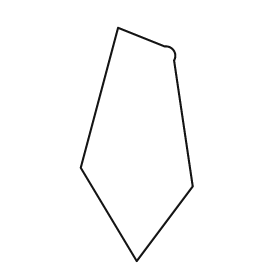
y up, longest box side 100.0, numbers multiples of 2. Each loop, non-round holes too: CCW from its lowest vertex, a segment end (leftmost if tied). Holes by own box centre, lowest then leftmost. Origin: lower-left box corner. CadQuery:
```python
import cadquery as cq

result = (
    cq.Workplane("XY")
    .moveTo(24.0, 0.0)
    .lineTo(48.0, 32.0)
    .lineTo(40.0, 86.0)
    .threePointArc((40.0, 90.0), (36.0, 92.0))
    .lineTo(16.0, 100.0)
    .lineTo(0.0, 40.0)
    .close()
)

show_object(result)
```